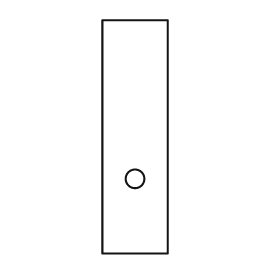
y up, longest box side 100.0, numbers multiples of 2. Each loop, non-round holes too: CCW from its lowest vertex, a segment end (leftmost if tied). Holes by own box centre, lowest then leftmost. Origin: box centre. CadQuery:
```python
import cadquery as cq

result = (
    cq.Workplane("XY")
    .moveTo(-14.0, -50.0)
    .lineTo(14.0, -50.0)
    .lineTo(14.0, 50.0)
    .lineTo(-14.0, 50.0)
    .close()
    .moveTo(0.0, -18.0)
    .circle(4.0)
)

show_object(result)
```